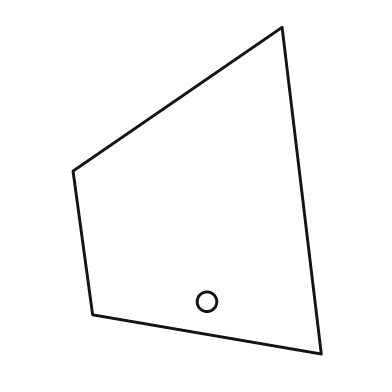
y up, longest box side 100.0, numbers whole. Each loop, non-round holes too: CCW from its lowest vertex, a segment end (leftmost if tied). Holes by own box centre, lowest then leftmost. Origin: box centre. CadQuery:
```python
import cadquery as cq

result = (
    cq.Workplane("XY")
    .moveTo(38.0, -50.0)
    .lineTo(26.0, 50.0)
    .lineTo(-38.0, 6.0)
    .lineTo(-32.0, -38.0)
    .close()
    .moveTo(3.0, -34.0)
    .circle(3.0)
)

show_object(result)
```